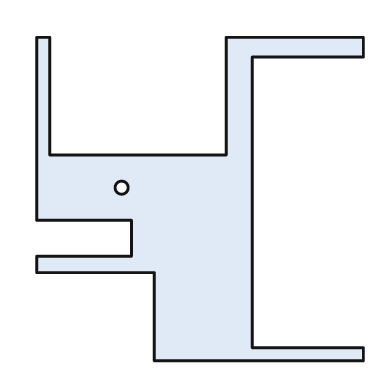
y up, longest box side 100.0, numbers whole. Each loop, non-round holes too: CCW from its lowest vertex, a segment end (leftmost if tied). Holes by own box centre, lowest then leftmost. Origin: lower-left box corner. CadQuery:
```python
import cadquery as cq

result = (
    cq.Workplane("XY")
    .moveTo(36.0, 0.0)
    .lineTo(100.0, 0.0)
    .lineTo(100.0, 4.0)
    .lineTo(66.0, 4.0)
    .lineTo(66.0, 93.0)
    .lineTo(100.0, 93.0)
    .lineTo(100.0, 99.0)
    .lineTo(58.0, 99.0)
    .lineTo(58.0, 63.0)
    .lineTo(4.0, 63.0)
    .lineTo(4.0, 99.0)
    .lineTo(0.0, 99.0)
    .lineTo(0.0, 43.0)
    .lineTo(29.0, 43.0)
    .lineTo(29.0, 32.0)
    .lineTo(0.0, 32.0)
    .lineTo(0.0, 27.0)
    .lineTo(36.0, 27.0)
    .close()
    .moveTo(26.0, 53.0)
    .circle(2.0)
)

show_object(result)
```